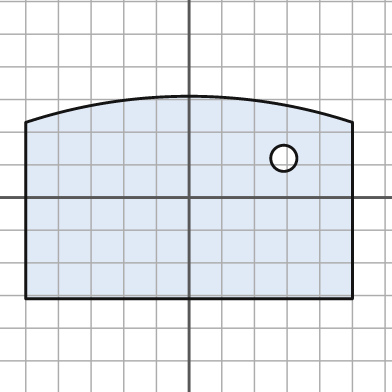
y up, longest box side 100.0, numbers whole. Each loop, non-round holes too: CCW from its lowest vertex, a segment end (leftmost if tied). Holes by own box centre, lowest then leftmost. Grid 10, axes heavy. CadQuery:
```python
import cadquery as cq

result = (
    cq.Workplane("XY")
    .moveTo(-50.0, -31.0)
    .lineTo(50.0, -31.0)
    .lineTo(50.0, 23.0)
    .threePointArc((0.0, 31.0), (-50.0, 23.0))
    .close()
    .moveTo(29.0, 12.0)
    .circle(4.0)
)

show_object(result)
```